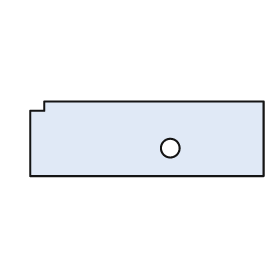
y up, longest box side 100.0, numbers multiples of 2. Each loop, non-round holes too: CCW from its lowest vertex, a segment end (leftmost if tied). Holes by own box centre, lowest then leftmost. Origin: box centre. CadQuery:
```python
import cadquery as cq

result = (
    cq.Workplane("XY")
    .moveTo(-50.0, -16.0)
    .lineTo(50.0, -16.0)
    .lineTo(50.0, 16.0)
    .lineTo(-44.0, 16.0)
    .lineTo(-44.0, 12.0)
    .lineTo(-50.0, 12.0)
    .close()
    .moveTo(10.0, -4.0)
    .circle(4.0)
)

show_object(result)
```